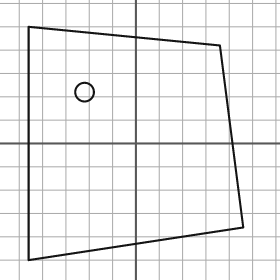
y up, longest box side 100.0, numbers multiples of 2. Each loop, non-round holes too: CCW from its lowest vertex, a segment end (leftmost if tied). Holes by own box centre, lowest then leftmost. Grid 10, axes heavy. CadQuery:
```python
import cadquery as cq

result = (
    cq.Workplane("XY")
    .moveTo(-46.0, -50.0)
    .lineTo(46.0, -36.0)
    .lineTo(36.0, 42.0)
    .lineTo(-46.0, 50.0)
    .close()
    .moveTo(-22.0, 22.0)
    .circle(4.0)
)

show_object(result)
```